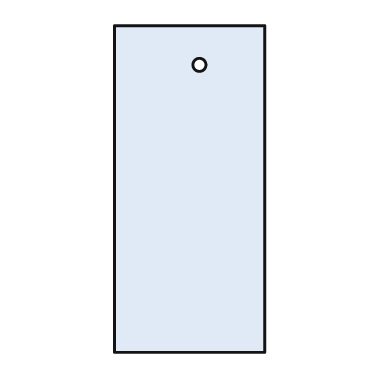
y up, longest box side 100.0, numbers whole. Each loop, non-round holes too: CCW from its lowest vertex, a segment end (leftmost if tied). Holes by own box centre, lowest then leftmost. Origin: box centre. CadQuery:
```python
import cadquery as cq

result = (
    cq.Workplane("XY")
    .moveTo(-23.0, -50.0)
    .lineTo(23.0, -50.0)
    .lineTo(23.0, 50.0)
    .lineTo(-23.0, 50.0)
    .close()
    .moveTo(3.0, 38.0)
    .circle(2.0)
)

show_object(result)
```